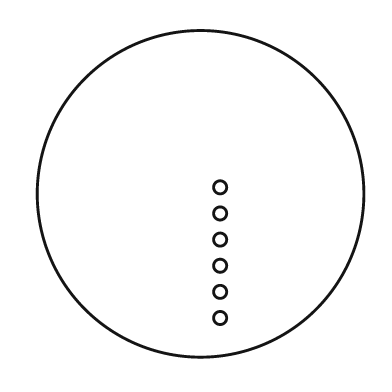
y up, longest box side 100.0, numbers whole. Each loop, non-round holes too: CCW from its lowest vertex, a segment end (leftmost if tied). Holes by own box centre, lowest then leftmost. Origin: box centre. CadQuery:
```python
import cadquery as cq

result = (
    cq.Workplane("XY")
    .moveTo(0.0, 0.0)
    .circle(50.0)
    .moveTo(6.0, -38.0)
    .circle(2.0)
    .moveTo(6.0, -30.0)
    .circle(2.0)
    .moveTo(6.0, -22.0)
    .circle(2.0)
    .moveTo(6.0, -14.0)
    .circle(2.0)
    .moveTo(6.0, -6.0)
    .circle(2.0)
    .moveTo(6.0, 2.0)
    .circle(2.0)
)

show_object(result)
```